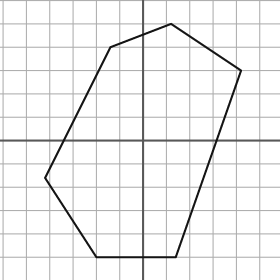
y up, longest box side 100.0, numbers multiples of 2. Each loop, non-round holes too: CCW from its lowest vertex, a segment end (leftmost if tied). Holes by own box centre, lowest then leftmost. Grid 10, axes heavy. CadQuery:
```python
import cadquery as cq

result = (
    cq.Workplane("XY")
    .moveTo(-20.0, -50.0)
    .lineTo(14.0, -50.0)
    .lineTo(42.0, 30.0)
    .lineTo(12.0, 50.0)
    .lineTo(-14.0, 40.0)
    .lineTo(-42.0, -16.0)
    .close()
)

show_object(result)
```